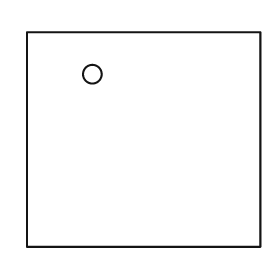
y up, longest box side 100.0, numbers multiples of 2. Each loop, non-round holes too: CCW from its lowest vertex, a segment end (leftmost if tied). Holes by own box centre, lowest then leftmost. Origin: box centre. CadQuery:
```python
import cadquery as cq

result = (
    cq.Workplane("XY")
    .moveTo(-50.0, -46.0)
    .lineTo(50.0, -46.0)
    .lineTo(50.0, 46.0)
    .lineTo(-50.0, 46.0)
    .close()
    .moveTo(-22.0, 28.0)
    .circle(4.0)
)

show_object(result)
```